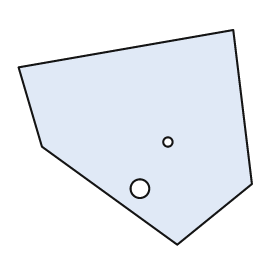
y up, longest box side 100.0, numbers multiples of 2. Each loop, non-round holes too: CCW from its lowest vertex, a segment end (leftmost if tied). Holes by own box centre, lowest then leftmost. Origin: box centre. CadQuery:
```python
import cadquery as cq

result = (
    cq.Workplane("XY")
    .moveTo(18.0, -46.0)
    .lineTo(50.0, -20.0)
    .lineTo(42.0, 46.0)
    .lineTo(-50.0, 30.0)
    .lineTo(-40.0, -4.0)
    .close()
    .moveTo(2.0, -22.0)
    .circle(4.0)
    .moveTo(14.0, -2.0)
    .circle(2.0)
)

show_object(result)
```